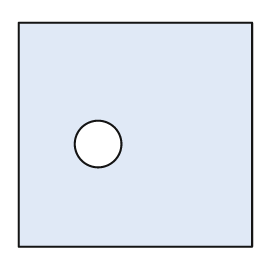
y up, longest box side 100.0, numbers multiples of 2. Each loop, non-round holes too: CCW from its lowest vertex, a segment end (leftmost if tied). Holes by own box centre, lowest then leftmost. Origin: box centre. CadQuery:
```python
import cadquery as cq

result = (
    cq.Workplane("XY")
    .moveTo(-50.0, -48.0)
    .lineTo(50.0, -48.0)
    .lineTo(50.0, 48.0)
    .lineTo(-50.0, 48.0)
    .close()
    .moveTo(-16.0, -4.0)
    .circle(10.0)
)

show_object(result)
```